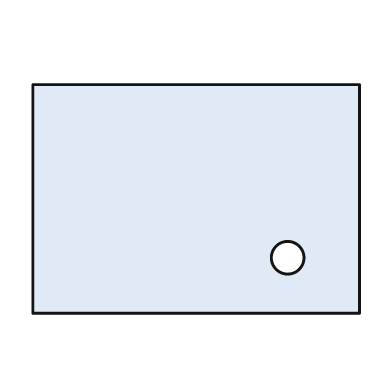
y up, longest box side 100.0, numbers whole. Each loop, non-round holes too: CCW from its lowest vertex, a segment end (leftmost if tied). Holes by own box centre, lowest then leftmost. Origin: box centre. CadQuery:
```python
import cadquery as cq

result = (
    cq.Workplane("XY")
    .moveTo(-50.0, -35.0)
    .lineTo(50.0, -35.0)
    .lineTo(50.0, 35.0)
    .lineTo(-50.0, 35.0)
    .close()
    .moveTo(28.0, -18.0)
    .circle(5.0)
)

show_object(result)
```